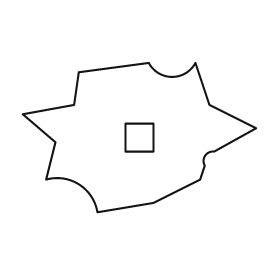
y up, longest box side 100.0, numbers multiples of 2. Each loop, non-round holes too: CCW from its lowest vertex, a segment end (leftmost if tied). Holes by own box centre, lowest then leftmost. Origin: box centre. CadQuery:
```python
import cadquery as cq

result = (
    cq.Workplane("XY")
    .moveTo(-18.0, -32.0)
    .lineTo(6.0, -28.0)
    .lineTo(26.0, -18.0)
    .lineTo(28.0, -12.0)
    .threePointArc((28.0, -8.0), (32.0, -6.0))
    .lineTo(50.0, 4.0)
    .lineTo(30.0, 14.0)
    .lineTo(24.0, 32.0)
    .threePointArc((14.0, 26.0), (4.0, 32.0))
    .lineTo(-26.0, 28.0)
    .lineTo(-28.0, 14.0)
    .lineTo(-50.0, 10.0)
    .lineTo(-36.0, -2.0)
    .lineTo(-40.0, -18.0)
    .threePointArc((-26.0, -20.0), (-18.0, -32.0))
    .close()
    .moveTo(-6.0, -6.0)
    .lineTo(6.0, -6.0)
    .lineTo(6.0, 6.0)
    .lineTo(-6.0, 6.0)
    .close()
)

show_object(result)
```